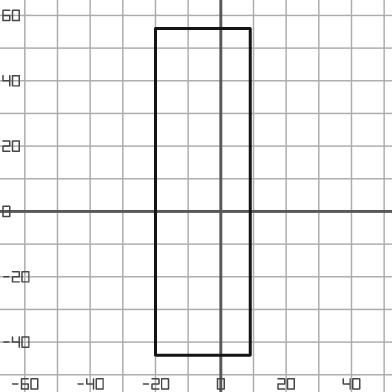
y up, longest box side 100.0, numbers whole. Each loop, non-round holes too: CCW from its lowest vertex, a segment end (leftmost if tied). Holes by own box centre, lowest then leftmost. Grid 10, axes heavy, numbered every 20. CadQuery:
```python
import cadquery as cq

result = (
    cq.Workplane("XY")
    .moveTo(-20.0, -44.0)
    .lineTo(9.0, -44.0)
    .lineTo(9.0, 56.0)
    .lineTo(-20.0, 56.0)
    .close()
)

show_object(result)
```